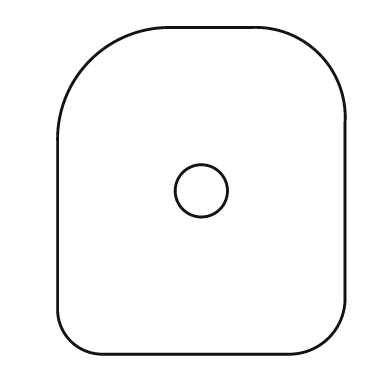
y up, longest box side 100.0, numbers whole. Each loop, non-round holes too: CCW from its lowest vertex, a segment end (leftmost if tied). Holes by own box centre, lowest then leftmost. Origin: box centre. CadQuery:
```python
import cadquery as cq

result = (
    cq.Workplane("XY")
    .moveTo(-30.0, -50.0)
    .lineTo(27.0, -50.0)
    .threePointArc((39.0, -45.0), (44.0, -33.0))
    .lineTo(44.0, 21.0)
    .threePointArc((36.0, 42.0), (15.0, 50.0))
    .lineTo(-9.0, 50.0)
    .threePointArc((-34.0, 40.0), (-44.0, 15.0))
    .lineTo(-44.0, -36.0)
    .threePointArc((-40.0, -46.0), (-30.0, -50.0))
    .close()
    .moveTo(0.0, 0.0)
    .circle(8.0)
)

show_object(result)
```